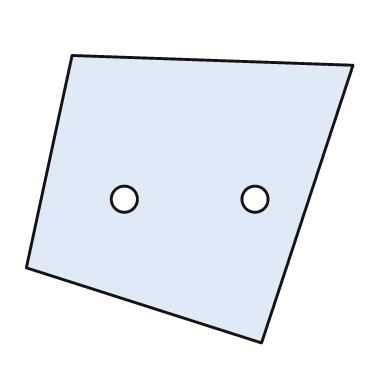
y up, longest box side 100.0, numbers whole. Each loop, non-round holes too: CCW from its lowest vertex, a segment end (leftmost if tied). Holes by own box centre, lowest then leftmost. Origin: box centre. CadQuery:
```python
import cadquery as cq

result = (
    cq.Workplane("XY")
    .moveTo(22.0, -44.0)
    .lineTo(50.0, 41.0)
    .lineTo(-36.0, 44.0)
    .lineTo(-50.0, -21.0)
    .close()
    .moveTo(-20.0, 0.0)
    .circle(4.0)
    .moveTo(20.0, 0.0)
    .circle(4.0)
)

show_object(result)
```